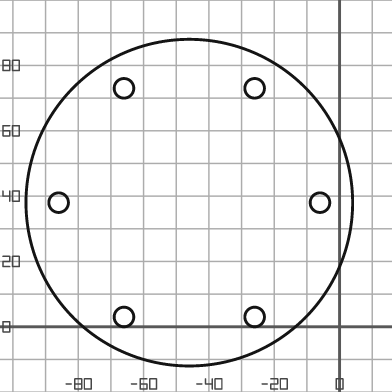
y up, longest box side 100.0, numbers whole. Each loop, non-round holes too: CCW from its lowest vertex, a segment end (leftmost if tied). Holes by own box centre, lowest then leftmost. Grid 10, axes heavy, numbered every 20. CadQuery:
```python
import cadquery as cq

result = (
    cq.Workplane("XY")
    .moveTo(-46.0, 38.0)
    .circle(50.0)
    .moveTo(-66.0, 3.0)
    .circle(3.0)
    .moveTo(-26.0, 3.0)
    .circle(3.0)
    .moveTo(-86.0, 38.0)
    .circle(3.0)
    .moveTo(-6.0, 38.0)
    .circle(3.0)
    .moveTo(-66.0, 73.0)
    .circle(3.0)
    .moveTo(-26.0, 73.0)
    .circle(3.0)
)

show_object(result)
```